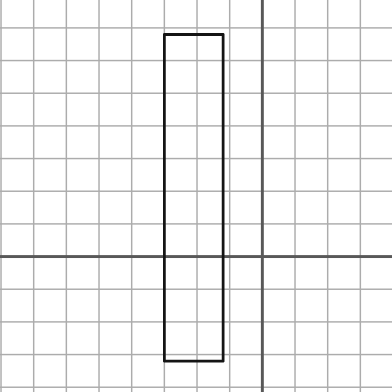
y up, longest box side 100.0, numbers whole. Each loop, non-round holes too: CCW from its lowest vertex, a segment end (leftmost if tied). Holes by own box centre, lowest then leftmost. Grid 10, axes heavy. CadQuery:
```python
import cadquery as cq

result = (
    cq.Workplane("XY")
    .moveTo(-30.0, -32.0)
    .lineTo(-12.0, -32.0)
    .lineTo(-12.0, 68.0)
    .lineTo(-30.0, 68.0)
    .close()
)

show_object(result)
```